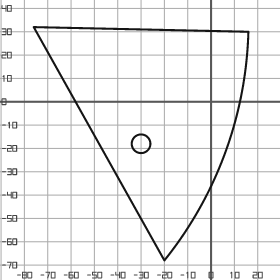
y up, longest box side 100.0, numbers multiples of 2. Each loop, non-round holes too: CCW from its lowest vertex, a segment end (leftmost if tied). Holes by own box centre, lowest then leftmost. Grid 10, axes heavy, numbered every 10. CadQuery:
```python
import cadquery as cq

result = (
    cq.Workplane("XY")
    .moveTo(-20.0, -68.0)
    .threePointArc((6.0, -22.0), (16.0, 30.0))
    .lineTo(-76.0, 32.0)
    .close()
    .moveTo(-30.0, -18.0)
    .circle(4.0)
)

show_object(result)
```